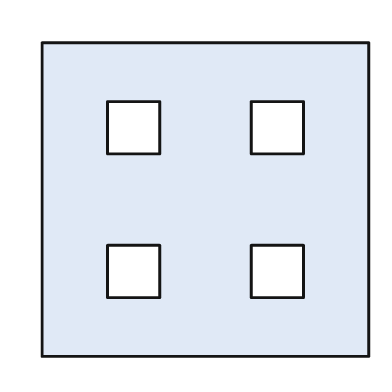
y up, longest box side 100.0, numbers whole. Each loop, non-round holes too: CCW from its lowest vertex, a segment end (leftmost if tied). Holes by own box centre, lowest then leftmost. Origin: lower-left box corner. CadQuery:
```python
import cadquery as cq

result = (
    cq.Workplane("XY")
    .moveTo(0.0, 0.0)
    .lineTo(100.0, 0.0)
    .lineTo(100.0, 96.0)
    .lineTo(0.0, 96.0)
    .close()
    .moveTo(20.0, 18.0)
    .lineTo(36.0, 18.0)
    .lineTo(36.0, 34.0)
    .lineTo(20.0, 34.0)
    .close()
    .moveTo(64.0, 18.0)
    .lineTo(80.0, 18.0)
    .lineTo(80.0, 34.0)
    .lineTo(64.0, 34.0)
    .close()
    .moveTo(20.0, 62.0)
    .lineTo(36.0, 62.0)
    .lineTo(36.0, 78.0)
    .lineTo(20.0, 78.0)
    .close()
    .moveTo(64.0, 62.0)
    .lineTo(80.0, 62.0)
    .lineTo(80.0, 78.0)
    .lineTo(64.0, 78.0)
    .close()
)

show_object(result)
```